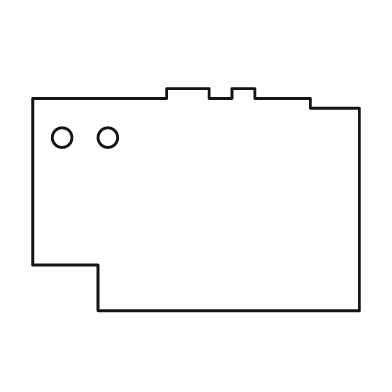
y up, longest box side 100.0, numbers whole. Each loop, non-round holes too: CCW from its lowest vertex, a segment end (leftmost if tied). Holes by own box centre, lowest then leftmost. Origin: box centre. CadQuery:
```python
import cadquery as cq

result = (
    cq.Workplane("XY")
    .moveTo(-30.0, -34.0)
    .lineTo(50.0, -34.0)
    .lineTo(50.0, 28.0)
    .lineTo(35.0, 28.0)
    .lineTo(35.0, 31.0)
    .lineTo(18.0, 31.0)
    .lineTo(18.0, 34.0)
    .lineTo(11.0, 34.0)
    .lineTo(11.0, 31.0)
    .lineTo(4.0, 31.0)
    .lineTo(4.0, 34.0)
    .lineTo(-9.0, 34.0)
    .lineTo(-9.0, 31.0)
    .lineTo(-50.0, 31.0)
    .lineTo(-50.0, -20.0)
    .lineTo(-30.0, -20.0)
    .close()
    .moveTo(-41.0, 19.0)
    .circle(3.0)
    .moveTo(-27.0, 19.0)
    .circle(3.0)
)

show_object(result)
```